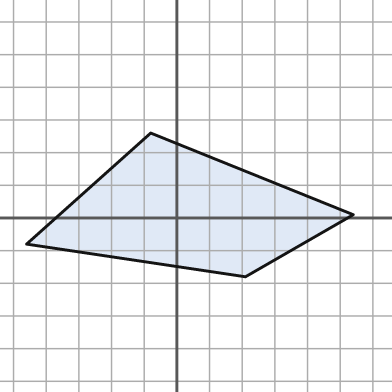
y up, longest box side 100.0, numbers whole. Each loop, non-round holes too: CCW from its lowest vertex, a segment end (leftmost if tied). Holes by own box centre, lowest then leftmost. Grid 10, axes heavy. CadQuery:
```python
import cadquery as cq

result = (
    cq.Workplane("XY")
    .moveTo(21.0, -18.0)
    .lineTo(54.0, 1.0)
    .lineTo(-8.0, 26.0)
    .lineTo(-46.0, -8.0)
    .close()
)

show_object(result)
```